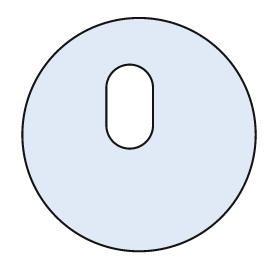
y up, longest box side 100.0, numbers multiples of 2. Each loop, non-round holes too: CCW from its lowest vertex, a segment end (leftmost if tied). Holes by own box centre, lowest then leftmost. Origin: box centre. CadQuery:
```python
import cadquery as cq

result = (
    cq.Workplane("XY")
    .moveTo(0.0, 0.0)
    .circle(50.0)
    .moveTo(-14.0, 4.0)
    .threePointArc((-4.0, -6.0), (6.0, 4.0))
    .lineTo(6.0, 20.0)
    .threePointArc((-4.0, 30.0), (-14.0, 20.0))
    .close()
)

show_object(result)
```